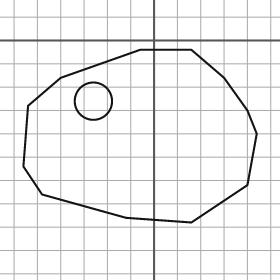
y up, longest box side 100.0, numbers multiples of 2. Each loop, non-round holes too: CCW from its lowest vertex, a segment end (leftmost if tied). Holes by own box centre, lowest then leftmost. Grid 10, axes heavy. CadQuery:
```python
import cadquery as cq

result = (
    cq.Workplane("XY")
    .moveTo(16.0, -78.0)
    .lineTo(40.0, -62.0)
    .lineTo(44.0, -40.0)
    .lineTo(40.0, -30.0)
    .lineTo(30.0, -16.0)
    .lineTo(16.0, -4.0)
    .lineTo(-6.0, -4.0)
    .lineTo(-40.0, -16.0)
    .lineTo(-54.0, -28.0)
    .lineTo(-56.0, -54.0)
    .lineTo(-48.0, -66.0)
    .lineTo(-12.0, -76.0)
    .close()
    .moveTo(-26.0, -26.0)
    .circle(8.0)
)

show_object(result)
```